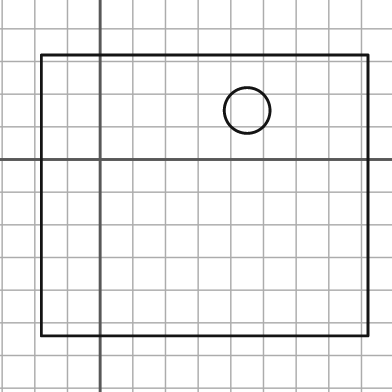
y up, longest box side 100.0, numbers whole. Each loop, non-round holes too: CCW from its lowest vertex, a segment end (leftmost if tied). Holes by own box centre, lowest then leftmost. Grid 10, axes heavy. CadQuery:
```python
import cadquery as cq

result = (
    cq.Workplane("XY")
    .moveTo(-18.0, -54.0)
    .lineTo(82.0, -54.0)
    .lineTo(82.0, 32.0)
    .lineTo(-18.0, 32.0)
    .close()
    .moveTo(45.0, 15.0)
    .circle(7.0)
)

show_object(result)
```